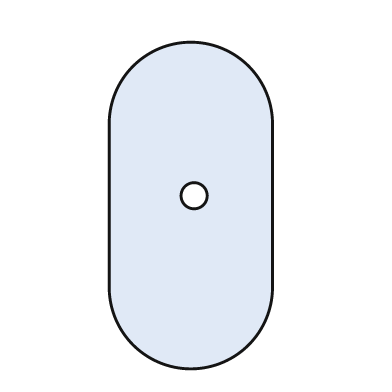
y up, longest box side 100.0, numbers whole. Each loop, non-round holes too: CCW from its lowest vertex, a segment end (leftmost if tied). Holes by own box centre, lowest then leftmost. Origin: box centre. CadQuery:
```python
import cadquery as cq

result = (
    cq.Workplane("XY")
    .moveTo(-25.0, -25.0)
    .threePointArc((0.0, -50.0), (25.0, -25.0))
    .lineTo(25.0, 25.0)
    .threePointArc((0.0, 50.0), (-25.0, 25.0))
    .close()
    .moveTo(1.0, 3.0)
    .circle(4.0)
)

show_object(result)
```